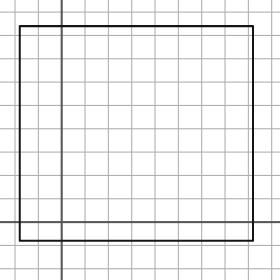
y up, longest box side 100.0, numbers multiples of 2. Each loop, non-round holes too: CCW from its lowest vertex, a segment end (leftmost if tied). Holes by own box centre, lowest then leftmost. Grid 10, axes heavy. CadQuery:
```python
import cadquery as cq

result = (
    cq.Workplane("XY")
    .moveTo(-18.0, -8.0)
    .lineTo(82.0, -8.0)
    .lineTo(82.0, 84.0)
    .lineTo(-18.0, 84.0)
    .close()
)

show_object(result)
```